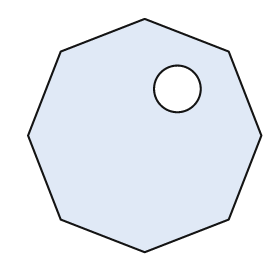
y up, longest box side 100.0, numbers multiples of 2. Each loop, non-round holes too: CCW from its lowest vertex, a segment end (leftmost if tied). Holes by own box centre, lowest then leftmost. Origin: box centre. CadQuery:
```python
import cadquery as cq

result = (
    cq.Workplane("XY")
    .moveTo(0.0, -50.0)
    .lineTo(36.0, -36.0)
    .lineTo(50.0, 0.0)
    .lineTo(36.0, 36.0)
    .lineTo(0.0, 50.0)
    .lineTo(-36.0, 36.0)
    .lineTo(-50.0, 0.0)
    .lineTo(-36.0, -36.0)
    .close()
    .moveTo(14.0, 20.0)
    .circle(10.0)
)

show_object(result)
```